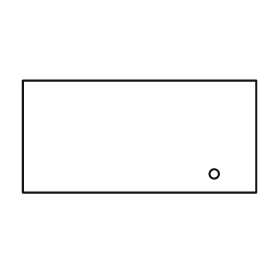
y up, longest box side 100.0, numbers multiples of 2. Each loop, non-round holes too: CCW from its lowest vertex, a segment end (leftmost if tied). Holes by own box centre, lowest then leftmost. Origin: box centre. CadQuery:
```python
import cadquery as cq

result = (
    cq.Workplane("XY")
    .moveTo(-50.0, -24.0)
    .lineTo(50.0, -24.0)
    .lineTo(50.0, 24.0)
    .lineTo(-50.0, 24.0)
    .close()
    .moveTo(32.0, -16.0)
    .circle(2.0)
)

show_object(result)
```